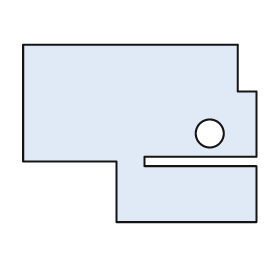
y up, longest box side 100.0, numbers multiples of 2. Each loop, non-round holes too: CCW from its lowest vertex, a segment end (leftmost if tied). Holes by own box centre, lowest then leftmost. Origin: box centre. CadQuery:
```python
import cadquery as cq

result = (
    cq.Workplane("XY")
    .moveTo(-10.0, -38.0)
    .lineTo(50.0, -38.0)
    .lineTo(50.0, -14.0)
    .lineTo(2.0, -14.0)
    .lineTo(2.0, -10.0)
    .lineTo(50.0, -10.0)
    .lineTo(50.0, 18.0)
    .lineTo(42.0, 18.0)
    .lineTo(42.0, 38.0)
    .lineTo(-50.0, 38.0)
    .lineTo(-50.0, -12.0)
    .lineTo(-10.0, -12.0)
    .close()
    .moveTo(30.0, 0.0)
    .circle(6.0)
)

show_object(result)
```